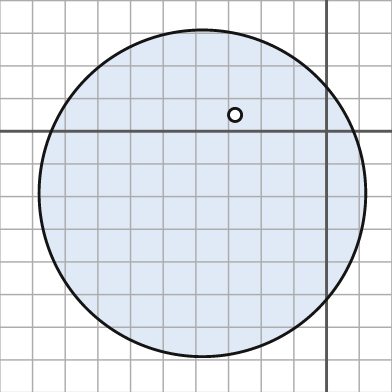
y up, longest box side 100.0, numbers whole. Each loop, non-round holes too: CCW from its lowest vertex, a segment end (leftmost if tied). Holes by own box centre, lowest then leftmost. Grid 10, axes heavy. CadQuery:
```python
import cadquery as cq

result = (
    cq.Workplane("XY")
    .moveTo(-38.0, -19.0)
    .circle(50.0)
    .moveTo(-28.0, 5.0)
    .circle(2.0)
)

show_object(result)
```